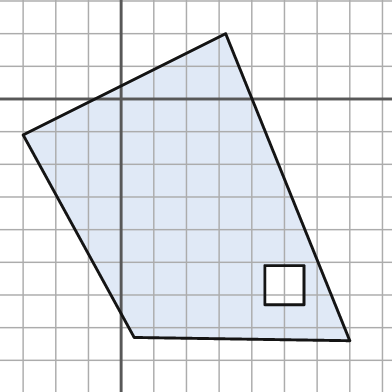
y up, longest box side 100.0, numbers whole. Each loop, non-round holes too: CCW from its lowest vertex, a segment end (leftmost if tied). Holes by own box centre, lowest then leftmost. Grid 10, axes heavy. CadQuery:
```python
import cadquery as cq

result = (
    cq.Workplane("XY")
    .moveTo(70.0, -74.0)
    .lineTo(32.0, 20.0)
    .lineTo(-30.0, -11.0)
    .lineTo(4.0, -73.0)
    .close()
    .moveTo(44.0, -63.0)
    .lineTo(56.0, -63.0)
    .lineTo(56.0, -51.0)
    .lineTo(44.0, -51.0)
    .close()
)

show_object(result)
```